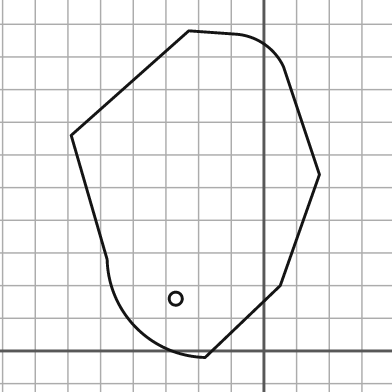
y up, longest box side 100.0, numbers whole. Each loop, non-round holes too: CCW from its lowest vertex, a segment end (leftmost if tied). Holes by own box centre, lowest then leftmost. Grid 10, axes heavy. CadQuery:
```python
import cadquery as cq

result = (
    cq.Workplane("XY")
    .moveTo(-18.0, -2.0)
    .lineTo(5.0, 20.0)
    .lineTo(17.0, 54.0)
    .lineTo(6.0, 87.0)
    .threePointArc((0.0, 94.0), (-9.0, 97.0))
    .lineTo(-23.0, 98.0)
    .lineTo(-59.0, 66.0)
    .lineTo(-48.0, 28.0)
    .threePointArc((-39.0, 7.0), (-18.0, -2.0))
    .close()
    .moveTo(-27.0, 16.0)
    .circle(2.0)
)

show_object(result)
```